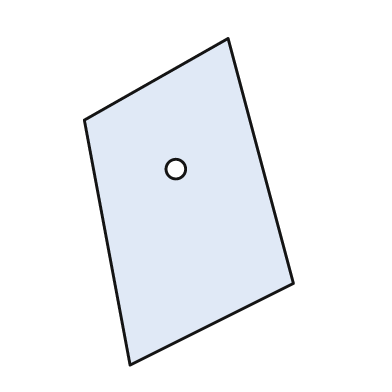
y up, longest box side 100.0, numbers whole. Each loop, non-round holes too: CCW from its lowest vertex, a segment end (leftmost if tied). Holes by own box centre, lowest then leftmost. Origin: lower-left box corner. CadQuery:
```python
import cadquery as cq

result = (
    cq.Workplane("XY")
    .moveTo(14.0, 0.0)
    .lineTo(64.0, 25.0)
    .lineTo(44.0, 100.0)
    .lineTo(0.0, 75.0)
    .close()
    .moveTo(28.0, 60.0)
    .circle(3.0)
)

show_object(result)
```